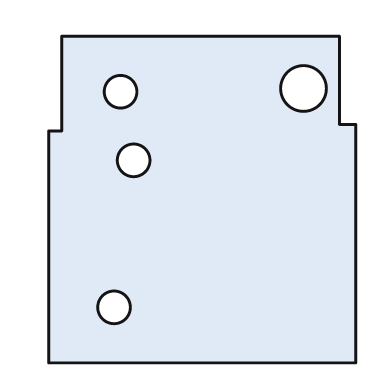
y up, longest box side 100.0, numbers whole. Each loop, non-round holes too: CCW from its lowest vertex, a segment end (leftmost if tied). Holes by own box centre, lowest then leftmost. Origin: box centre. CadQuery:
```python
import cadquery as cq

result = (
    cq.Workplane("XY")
    .moveTo(-47.0, -50.0)
    .lineTo(47.0, -50.0)
    .lineTo(47.0, 23.0)
    .lineTo(42.0, 23.0)
    .lineTo(42.0, 50.0)
    .lineTo(-43.0, 50.0)
    .lineTo(-43.0, 21.0)
    .lineTo(-47.0, 21.0)
    .close()
    .moveTo(-27.0, -33.0)
    .circle(5.0)
    .moveTo(-21.0, 12.0)
    .circle(5.0)
    .moveTo(-25.0, 33.0)
    .circle(5.0)
    .moveTo(31.0, 34.0)
    .circle(7.0)
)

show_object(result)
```